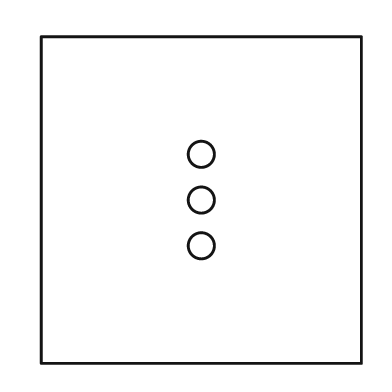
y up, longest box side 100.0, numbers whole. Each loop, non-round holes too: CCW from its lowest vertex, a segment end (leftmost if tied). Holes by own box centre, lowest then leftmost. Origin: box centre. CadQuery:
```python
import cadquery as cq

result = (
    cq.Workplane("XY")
    .moveTo(-49.0, -50.0)
    .lineTo(49.0, -50.0)
    .lineTo(49.0, 50.0)
    .lineTo(-49.0, 50.0)
    .close()
    .moveTo(0.0, -14.0)
    .circle(4.0)
    .moveTo(0.0, 0.0)
    .circle(4.0)
    .moveTo(0.0, 14.0)
    .circle(4.0)
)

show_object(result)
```